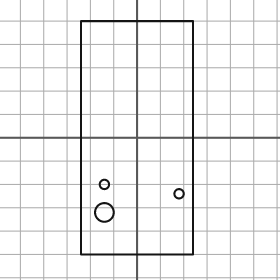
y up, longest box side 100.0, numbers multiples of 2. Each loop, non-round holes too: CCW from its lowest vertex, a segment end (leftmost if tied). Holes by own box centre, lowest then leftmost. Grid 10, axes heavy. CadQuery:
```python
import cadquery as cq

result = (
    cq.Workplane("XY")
    .moveTo(-24.0, -50.0)
    .lineTo(24.0, -50.0)
    .lineTo(24.0, 50.0)
    .lineTo(-24.0, 50.0)
    .close()
    .moveTo(-14.0, -32.0)
    .circle(4.0)
    .moveTo(18.0, -24.0)
    .circle(2.0)
    .moveTo(-14.0, -20.0)
    .circle(2.0)
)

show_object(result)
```